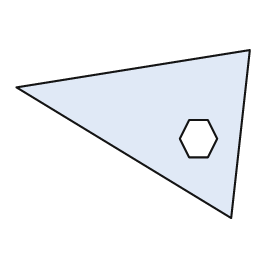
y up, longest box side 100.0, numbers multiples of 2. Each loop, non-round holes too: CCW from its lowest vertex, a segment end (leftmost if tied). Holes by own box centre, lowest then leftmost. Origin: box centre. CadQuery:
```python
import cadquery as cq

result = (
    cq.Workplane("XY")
    .moveTo(42.0, -36.0)
    .lineTo(50.0, 36.0)
    .lineTo(-50.0, 20.0)
    .close()
    .moveTo(24.0, -10.0)
    .lineTo(32.0, -10.0)
    .lineTo(36.0, -2.0)
    .lineTo(32.0, 6.0)
    .lineTo(24.0, 6.0)
    .lineTo(20.0, -2.0)
    .close()
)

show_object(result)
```